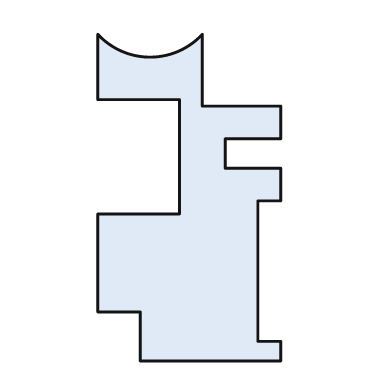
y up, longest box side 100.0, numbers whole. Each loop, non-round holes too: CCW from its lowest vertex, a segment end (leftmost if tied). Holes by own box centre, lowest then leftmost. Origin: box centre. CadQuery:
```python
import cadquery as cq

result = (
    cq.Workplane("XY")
    .moveTo(-15.0, -50.0)
    .lineTo(28.0, -50.0)
    .lineTo(28.0, -44.0)
    .lineTo(21.0, -44.0)
    .lineTo(21.0, -1.0)
    .lineTo(28.0, -1.0)
    .lineTo(28.0, 9.0)
    .lineTo(11.0, 9.0)
    .lineTo(11.0, 18.0)
    .lineTo(28.0, 18.0)
    .lineTo(28.0, 28.0)
    .lineTo(4.0, 28.0)
    .lineTo(4.0, 50.0)
    .threePointArc((-12.0, 43.0), (-28.0, 50.0))
    .lineTo(-28.0, 30.0)
    .lineTo(-3.0, 30.0)
    .lineTo(-3.0, -5.0)
    .lineTo(-28.0, -5.0)
    .lineTo(-28.0, -35.0)
    .lineTo(-15.0, -35.0)
    .close()
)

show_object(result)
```